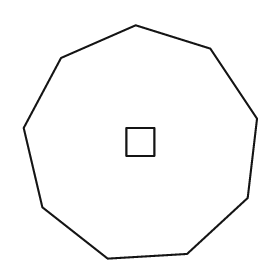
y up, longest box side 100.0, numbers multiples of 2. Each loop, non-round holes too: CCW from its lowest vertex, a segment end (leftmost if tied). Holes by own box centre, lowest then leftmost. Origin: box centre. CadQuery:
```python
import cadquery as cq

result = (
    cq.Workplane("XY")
    .moveTo(-14.0, -50.0)
    .lineTo(20.0, -48.0)
    .lineTo(46.0, -24.0)
    .lineTo(50.0, 10.0)
    .lineTo(30.0, 40.0)
    .lineTo(-2.0, 50.0)
    .lineTo(-34.0, 36.0)
    .lineTo(-50.0, 6.0)
    .lineTo(-42.0, -28.0)
    .close()
    .moveTo(-6.0, -6.0)
    .lineTo(6.0, -6.0)
    .lineTo(6.0, 6.0)
    .lineTo(-6.0, 6.0)
    .close()
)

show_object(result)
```